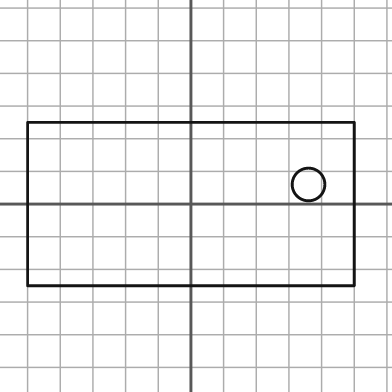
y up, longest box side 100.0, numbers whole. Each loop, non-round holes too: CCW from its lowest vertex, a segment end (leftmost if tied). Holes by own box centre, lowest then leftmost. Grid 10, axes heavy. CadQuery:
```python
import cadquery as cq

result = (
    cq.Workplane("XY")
    .moveTo(-50.0, -25.0)
    .lineTo(50.0, -25.0)
    .lineTo(50.0, 25.0)
    .lineTo(-50.0, 25.0)
    .close()
    .moveTo(36.0, 6.0)
    .circle(5.0)
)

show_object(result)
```